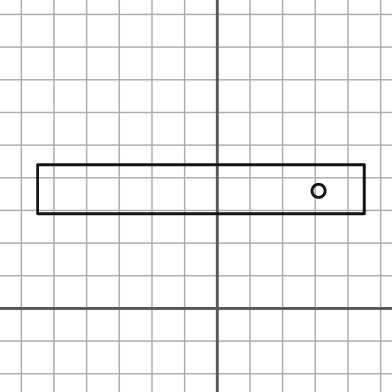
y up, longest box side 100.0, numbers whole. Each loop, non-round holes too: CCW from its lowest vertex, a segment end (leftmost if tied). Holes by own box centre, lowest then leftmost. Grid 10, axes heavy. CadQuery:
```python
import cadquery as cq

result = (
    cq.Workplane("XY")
    .moveTo(-55.0, 29.0)
    .lineTo(45.0, 29.0)
    .lineTo(45.0, 44.0)
    .lineTo(-55.0, 44.0)
    .close()
    .moveTo(31.0, 36.0)
    .circle(2.0)
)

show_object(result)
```